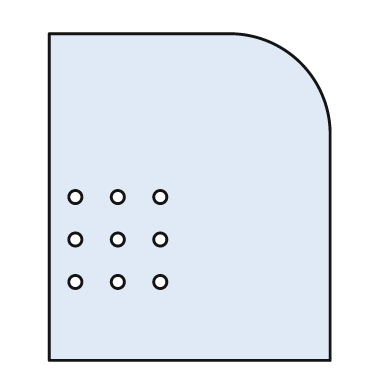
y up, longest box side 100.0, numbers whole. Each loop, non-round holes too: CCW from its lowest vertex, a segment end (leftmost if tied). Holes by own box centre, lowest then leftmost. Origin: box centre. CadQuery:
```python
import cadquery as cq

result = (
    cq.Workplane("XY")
    .moveTo(-43.0, -50.0)
    .lineTo(43.0, -50.0)
    .lineTo(43.0, 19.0)
    .threePointArc((34.0, 41.0), (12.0, 50.0))
    .lineTo(-43.0, 50.0)
    .close()
    .moveTo(-35.0, -26.0)
    .circle(2.0)
    .moveTo(-22.0, -26.0)
    .circle(2.0)
    .moveTo(-9.0, -26.0)
    .circle(2.0)
    .moveTo(-35.0, -13.0)
    .circle(2.0)
    .moveTo(-22.0, -13.0)
    .circle(2.0)
    .moveTo(-9.0, -13.0)
    .circle(2.0)
    .moveTo(-35.0, 0.0)
    .circle(2.0)
    .moveTo(-22.0, 0.0)
    .circle(2.0)
    .moveTo(-9.0, 0.0)
    .circle(2.0)
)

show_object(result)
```